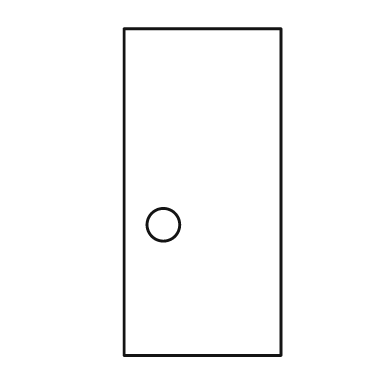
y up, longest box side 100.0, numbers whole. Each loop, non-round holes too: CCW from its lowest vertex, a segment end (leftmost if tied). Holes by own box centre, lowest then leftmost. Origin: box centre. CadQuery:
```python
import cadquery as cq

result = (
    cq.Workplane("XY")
    .moveTo(-24.0, -50.0)
    .lineTo(24.0, -50.0)
    .lineTo(24.0, 50.0)
    .lineTo(-24.0, 50.0)
    .close()
    .moveTo(-12.0, -10.0)
    .circle(5.0)
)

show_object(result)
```